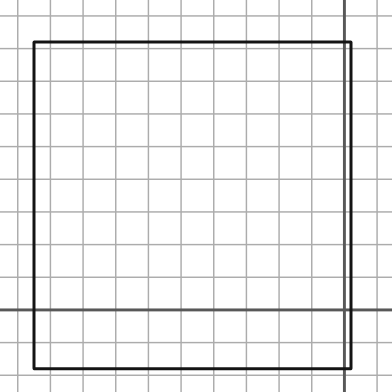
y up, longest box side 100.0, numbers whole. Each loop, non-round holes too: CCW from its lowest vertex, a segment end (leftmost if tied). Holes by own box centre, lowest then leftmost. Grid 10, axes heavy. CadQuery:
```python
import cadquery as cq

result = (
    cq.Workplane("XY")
    .moveTo(-95.0, -18.0)
    .lineTo(2.0, -18.0)
    .lineTo(2.0, 82.0)
    .lineTo(-95.0, 82.0)
    .close()
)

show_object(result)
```